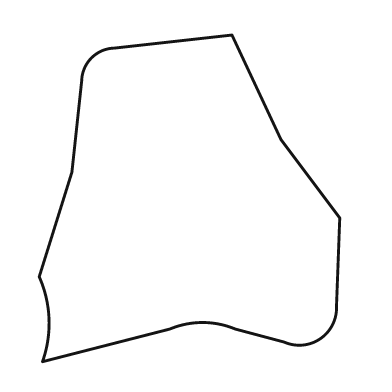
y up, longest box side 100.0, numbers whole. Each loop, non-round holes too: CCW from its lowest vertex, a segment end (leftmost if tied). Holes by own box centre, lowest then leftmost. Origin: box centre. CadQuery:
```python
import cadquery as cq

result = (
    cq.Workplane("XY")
    .moveTo(-45.0, -50.0)
    .lineTo(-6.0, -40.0)
    .threePointArc((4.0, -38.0), (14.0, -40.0))
    .lineTo(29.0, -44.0)
    .threePointArc((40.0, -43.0), (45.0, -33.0))
    .lineTo(46.0, -6.0)
    .lineTo(28.0, 18.0)
    .lineTo(13.0, 50.0)
    .lineTo(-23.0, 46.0)
    .threePointArc((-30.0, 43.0), (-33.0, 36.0))
    .lineTo(-36.0, 8.0)
    .lineTo(-46.0, -24.0)
    .threePointArc((-43.0, -37.0), (-45.0, -50.0))
    .close()
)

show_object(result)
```